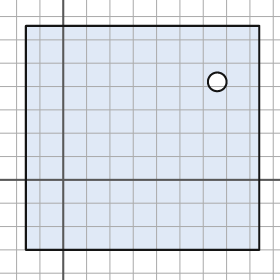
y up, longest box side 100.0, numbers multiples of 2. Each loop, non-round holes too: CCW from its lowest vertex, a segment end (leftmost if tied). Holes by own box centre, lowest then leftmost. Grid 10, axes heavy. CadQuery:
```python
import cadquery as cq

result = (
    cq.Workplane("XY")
    .moveTo(-16.0, -30.0)
    .lineTo(84.0, -30.0)
    .lineTo(84.0, 66.0)
    .lineTo(-16.0, 66.0)
    .close()
    .moveTo(66.0, 42.0)
    .circle(4.0)
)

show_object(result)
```